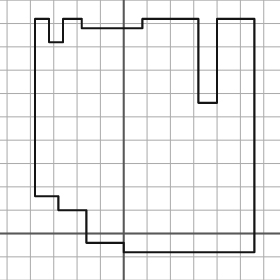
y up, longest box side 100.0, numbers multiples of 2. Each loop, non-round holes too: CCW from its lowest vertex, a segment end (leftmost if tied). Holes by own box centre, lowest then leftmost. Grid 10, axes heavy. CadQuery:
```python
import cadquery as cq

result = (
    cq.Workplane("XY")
    .moveTo(0.0, -8.0)
    .lineTo(56.0, -8.0)
    .lineTo(56.0, 92.0)
    .lineTo(40.0, 92.0)
    .lineTo(40.0, 56.0)
    .lineTo(32.0, 56.0)
    .lineTo(32.0, 92.0)
    .lineTo(8.0, 92.0)
    .lineTo(8.0, 88.0)
    .lineTo(-18.0, 88.0)
    .lineTo(-18.0, 92.0)
    .lineTo(-26.0, 92.0)
    .lineTo(-26.0, 82.0)
    .lineTo(-32.0, 82.0)
    .lineTo(-32.0, 92.0)
    .lineTo(-38.0, 92.0)
    .lineTo(-38.0, 16.0)
    .lineTo(-28.0, 16.0)
    .lineTo(-28.0, 10.0)
    .lineTo(-16.0, 10.0)
    .lineTo(-16.0, -4.0)
    .lineTo(0.0, -4.0)
    .close()
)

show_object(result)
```